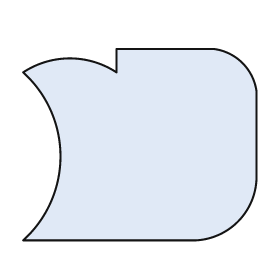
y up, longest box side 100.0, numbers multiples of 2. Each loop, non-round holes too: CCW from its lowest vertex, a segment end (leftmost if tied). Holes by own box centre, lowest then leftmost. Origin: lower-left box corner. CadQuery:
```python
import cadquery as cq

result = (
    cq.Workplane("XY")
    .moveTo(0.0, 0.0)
    .lineTo(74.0, 0.0)
    .threePointArc((92.0, 8.0), (100.0, 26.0))
    .lineTo(100.0, 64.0)
    .threePointArc((94.0, 76.0), (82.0, 82.0))
    .lineTo(40.0, 82.0)
    .lineTo(40.0, 72.0)
    .threePointArc((20.0, 78.0), (0.0, 72.0))
    .threePointArc((16.0, 36.0), (0.0, 0.0))
    .close()
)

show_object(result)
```